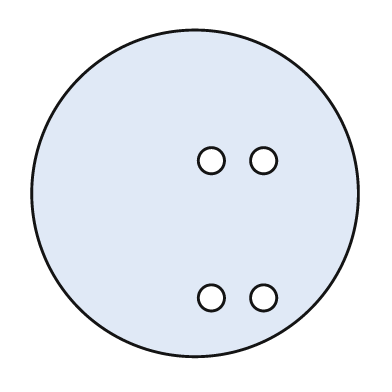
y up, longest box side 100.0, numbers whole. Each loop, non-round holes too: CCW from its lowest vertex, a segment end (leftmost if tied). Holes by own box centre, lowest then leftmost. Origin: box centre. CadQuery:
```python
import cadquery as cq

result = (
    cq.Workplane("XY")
    .moveTo(0.0, 0.0)
    .circle(50.0)
    .moveTo(5.0, -32.0)
    .circle(4.0)
    .moveTo(21.0, -32.0)
    .circle(4.0)
    .moveTo(5.0, 10.0)
    .circle(4.0)
    .moveTo(21.0, 10.0)
    .circle(4.0)
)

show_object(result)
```